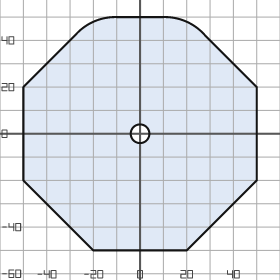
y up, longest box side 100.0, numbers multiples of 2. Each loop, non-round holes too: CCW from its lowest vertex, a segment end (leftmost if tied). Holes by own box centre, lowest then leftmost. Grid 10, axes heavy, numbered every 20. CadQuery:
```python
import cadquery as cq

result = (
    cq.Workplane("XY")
    .moveTo(-20.0, -50.0)
    .lineTo(20.0, -50.0)
    .lineTo(50.0, -20.0)
    .lineTo(50.0, 20.0)
    .lineTo(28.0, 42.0)
    .threePointArc((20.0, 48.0), (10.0, 50.0))
    .lineTo(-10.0, 50.0)
    .threePointArc((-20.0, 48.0), (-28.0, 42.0))
    .lineTo(-50.0, 20.0)
    .lineTo(-50.0, -20.0)
    .close()
    .moveTo(0.0, 0.0)
    .circle(4.0)
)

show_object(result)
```